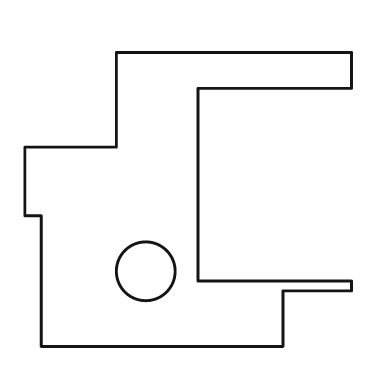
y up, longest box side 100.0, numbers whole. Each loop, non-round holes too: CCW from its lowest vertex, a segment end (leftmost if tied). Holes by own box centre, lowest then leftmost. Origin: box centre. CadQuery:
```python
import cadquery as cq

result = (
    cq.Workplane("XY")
    .moveTo(-45.0, -45.0)
    .lineTo(29.0, -45.0)
    .lineTo(29.0, -28.0)
    .lineTo(50.0, -28.0)
    .lineTo(50.0, -25.0)
    .lineTo(3.0, -25.0)
    .lineTo(3.0, 34.0)
    .lineTo(50.0, 34.0)
    .lineTo(50.0, 45.0)
    .lineTo(-22.0, 45.0)
    .lineTo(-22.0, 16.0)
    .lineTo(-50.0, 16.0)
    .lineTo(-50.0, -5.0)
    .lineTo(-45.0, -5.0)
    .close()
    .moveTo(-13.0, -22.0)
    .circle(9.0)
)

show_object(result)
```